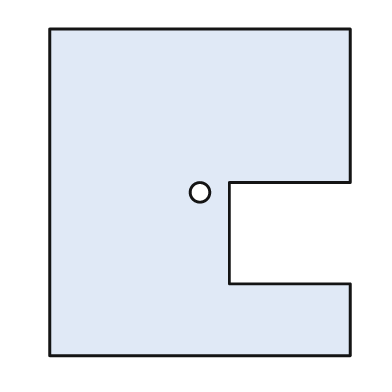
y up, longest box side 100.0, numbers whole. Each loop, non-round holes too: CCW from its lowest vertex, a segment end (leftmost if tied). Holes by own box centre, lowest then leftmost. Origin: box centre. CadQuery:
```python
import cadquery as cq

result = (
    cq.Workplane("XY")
    .moveTo(-46.0, -50.0)
    .lineTo(46.0, -50.0)
    .lineTo(46.0, -28.0)
    .lineTo(9.0, -28.0)
    .lineTo(9.0, 3.0)
    .lineTo(46.0, 3.0)
    .lineTo(46.0, 50.0)
    .lineTo(-46.0, 50.0)
    .close()
    .moveTo(0.0, 0.0)
    .circle(3.0)
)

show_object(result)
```